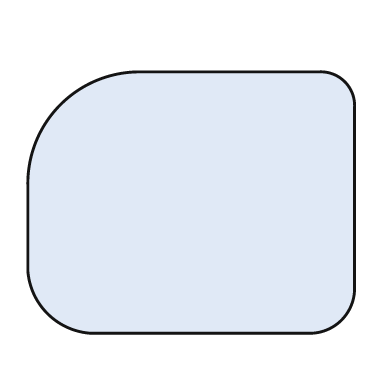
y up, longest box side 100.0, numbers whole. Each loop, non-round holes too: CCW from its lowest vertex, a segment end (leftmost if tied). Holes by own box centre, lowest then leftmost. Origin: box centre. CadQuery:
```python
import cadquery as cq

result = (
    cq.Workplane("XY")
    .moveTo(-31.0, -40.0)
    .lineTo(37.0, -40.0)
    .threePointArc((46.0, -36.0), (50.0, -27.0))
    .lineTo(50.0, 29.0)
    .threePointArc((47.0, 37.0), (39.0, 40.0))
    .lineTo(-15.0, 40.0)
    .threePointArc((-40.0, 30.0), (-50.0, 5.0))
    .lineTo(-50.0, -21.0)
    .threePointArc((-44.0, -34.0), (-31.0, -40.0))
    .close()
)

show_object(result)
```